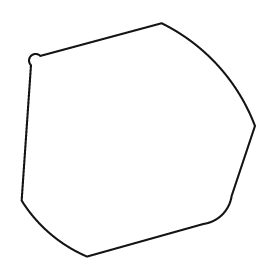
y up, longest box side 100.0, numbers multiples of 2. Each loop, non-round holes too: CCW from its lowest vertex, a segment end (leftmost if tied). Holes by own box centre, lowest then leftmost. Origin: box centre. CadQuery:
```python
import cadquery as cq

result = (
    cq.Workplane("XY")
    .moveTo(-22.0, -50.0)
    .lineTo(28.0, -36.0)
    .threePointArc((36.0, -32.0), (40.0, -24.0))
    .lineTo(50.0, 6.0)
    .threePointArc((34.0, 32.0), (10.0, 50.0))
    .lineTo(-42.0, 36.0)
    .threePointArc((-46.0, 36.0), (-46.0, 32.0))
    .lineTo(-50.0, -26.0)
    .threePointArc((-38.0, -40.0), (-22.0, -50.0))
    .close()
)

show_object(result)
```